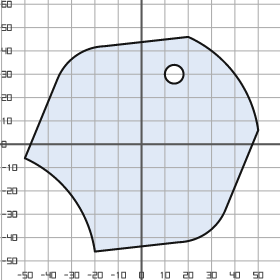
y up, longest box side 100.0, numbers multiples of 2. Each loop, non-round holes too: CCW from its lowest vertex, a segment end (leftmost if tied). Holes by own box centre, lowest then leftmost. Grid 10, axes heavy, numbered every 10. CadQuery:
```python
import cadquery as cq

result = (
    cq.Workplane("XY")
    .moveTo(-20.0, -46.0)
    .lineTo(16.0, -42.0)
    .threePointArc((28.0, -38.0), (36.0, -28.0))
    .lineTo(50.0, 6.0)
    .threePointArc((40.0, 30.0), (20.0, 46.0))
    .lineTo(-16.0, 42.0)
    .threePointArc((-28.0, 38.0), (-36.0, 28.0))
    .lineTo(-50.0, -6.0)
    .threePointArc((-30.0, -22.0), (-20.0, -46.0))
    .close()
    .moveTo(14.0, 30.0)
    .circle(4.0)
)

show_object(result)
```